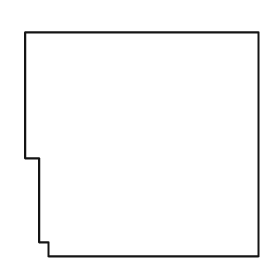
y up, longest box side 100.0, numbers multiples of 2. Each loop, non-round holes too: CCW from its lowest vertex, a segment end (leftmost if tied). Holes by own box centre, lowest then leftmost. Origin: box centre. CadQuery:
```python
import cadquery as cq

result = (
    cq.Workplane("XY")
    .moveTo(-40.0, -48.0)
    .lineTo(50.0, -48.0)
    .lineTo(50.0, 48.0)
    .lineTo(-50.0, 48.0)
    .lineTo(-50.0, -6.0)
    .lineTo(-44.0, -6.0)
    .lineTo(-44.0, -42.0)
    .lineTo(-40.0, -42.0)
    .close()
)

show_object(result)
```